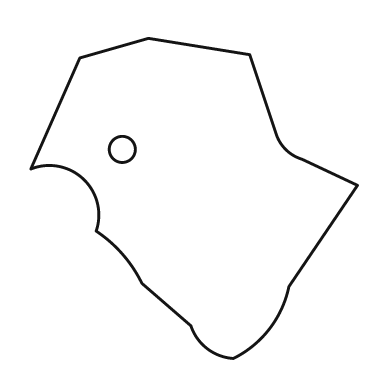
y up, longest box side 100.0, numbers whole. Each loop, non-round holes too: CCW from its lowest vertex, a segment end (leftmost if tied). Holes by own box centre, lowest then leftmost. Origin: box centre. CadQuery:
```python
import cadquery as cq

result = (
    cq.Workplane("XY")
    .moveTo(12.0, -49.0)
    .threePointArc((23.0, -40.0), (29.0, -27.0))
    .lineTo(50.0, 4.0)
    .lineTo(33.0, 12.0)
    .threePointArc((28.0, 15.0), (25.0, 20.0))
    .lineTo(17.0, 44.0)
    .lineTo(-14.0, 49.0)
    .lineTo(-35.0, 43.0)
    .lineTo(-50.0, 9.0)
    .threePointArc((-34.0, 6.0), (-30.0, -10.0))
    .threePointArc((-22.0, -17.0), (-16.0, -26.0))
    .lineTo(-1.0, -39.0)
    .threePointArc((4.0, -46.0), (12.0, -49.0))
    .close()
    .moveTo(-22.0, 15.0)
    .circle(4.0)
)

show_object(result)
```